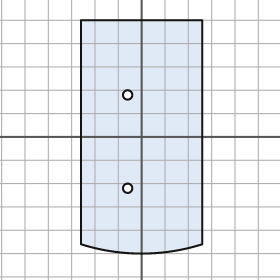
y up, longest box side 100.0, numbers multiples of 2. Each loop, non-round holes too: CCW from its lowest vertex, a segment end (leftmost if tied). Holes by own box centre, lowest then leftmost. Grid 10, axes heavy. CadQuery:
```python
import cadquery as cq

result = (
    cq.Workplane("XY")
    .moveTo(-26.0, -46.0)
    .threePointArc((0.0, -50.0), (26.0, -46.0))
    .lineTo(26.0, 50.0)
    .lineTo(-26.0, 50.0)
    .close()
    .moveTo(-6.0, -22.0)
    .circle(2.0)
    .moveTo(-6.0, 18.0)
    .circle(2.0)
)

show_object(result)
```